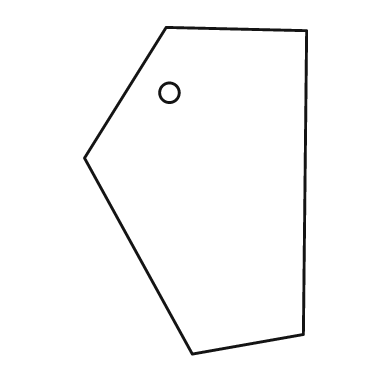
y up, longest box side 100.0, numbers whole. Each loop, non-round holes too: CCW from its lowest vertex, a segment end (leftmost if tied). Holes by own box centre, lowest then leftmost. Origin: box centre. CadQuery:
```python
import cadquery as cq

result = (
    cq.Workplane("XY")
    .moveTo(-1.0, -50.0)
    .lineTo(33.0, -44.0)
    .lineTo(34.0, 49.0)
    .lineTo(-9.0, 50.0)
    .lineTo(-34.0, 10.0)
    .close()
    .moveTo(-8.0, 30.0)
    .circle(3.0)
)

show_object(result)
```